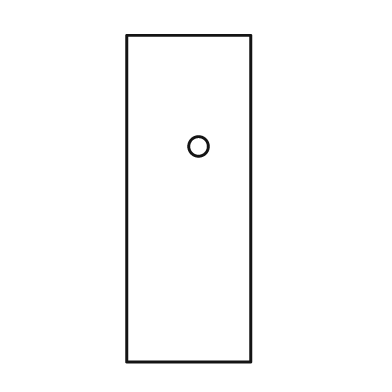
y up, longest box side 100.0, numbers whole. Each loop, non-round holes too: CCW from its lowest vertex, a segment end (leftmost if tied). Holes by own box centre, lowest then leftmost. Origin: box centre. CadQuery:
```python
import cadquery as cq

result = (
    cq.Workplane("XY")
    .moveTo(-19.0, -50.0)
    .lineTo(19.0, -50.0)
    .lineTo(19.0, 50.0)
    .lineTo(-19.0, 50.0)
    .close()
    .moveTo(3.0, 16.0)
    .circle(3.0)
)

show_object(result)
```